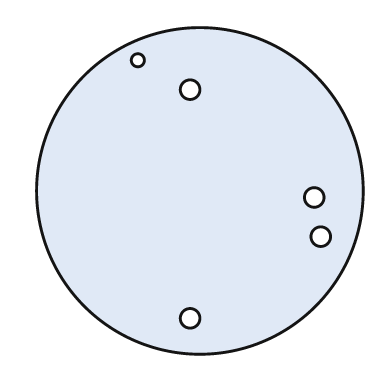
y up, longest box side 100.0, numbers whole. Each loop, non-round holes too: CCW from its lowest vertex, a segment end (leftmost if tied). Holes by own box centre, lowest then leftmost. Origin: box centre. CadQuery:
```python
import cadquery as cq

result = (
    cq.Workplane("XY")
    .moveTo(0.0, 0.0)
    .circle(50.0)
    .moveTo(-3.0, -39.0)
    .circle(3.0)
    .moveTo(37.0, -14.0)
    .circle(3.0)
    .moveTo(35.0, -2.0)
    .circle(3.0)
    .moveTo(-3.0, 31.0)
    .circle(3.0)
    .moveTo(-19.0, 40.0)
    .circle(2.0)
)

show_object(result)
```